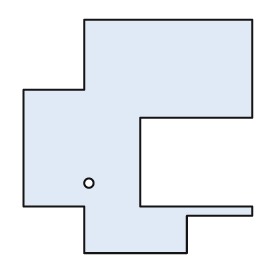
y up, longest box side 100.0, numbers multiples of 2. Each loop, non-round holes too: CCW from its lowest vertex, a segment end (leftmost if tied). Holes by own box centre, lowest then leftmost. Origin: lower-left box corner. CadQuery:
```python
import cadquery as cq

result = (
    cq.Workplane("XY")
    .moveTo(26.0, 0.0)
    .lineTo(70.0, 0.0)
    .lineTo(70.0, 16.0)
    .lineTo(98.0, 16.0)
    .lineTo(98.0, 20.0)
    .lineTo(50.0, 20.0)
    .lineTo(50.0, 58.0)
    .lineTo(98.0, 58.0)
    .lineTo(98.0, 100.0)
    .lineTo(26.0, 100.0)
    .lineTo(26.0, 70.0)
    .lineTo(0.0, 70.0)
    .lineTo(0.0, 20.0)
    .lineTo(26.0, 20.0)
    .close()
    .moveTo(28.0, 30.0)
    .circle(2.0)
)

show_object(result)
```